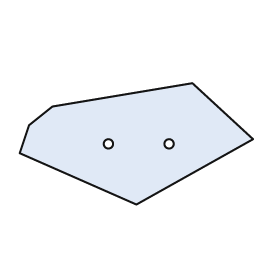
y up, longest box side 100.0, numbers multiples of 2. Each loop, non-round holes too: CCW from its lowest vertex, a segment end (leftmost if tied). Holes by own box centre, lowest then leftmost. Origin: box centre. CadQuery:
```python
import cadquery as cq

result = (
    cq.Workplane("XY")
    .moveTo(0.0, -26.0)
    .lineTo(50.0, 2.0)
    .lineTo(24.0, 26.0)
    .lineTo(-36.0, 16.0)
    .lineTo(-46.0, 8.0)
    .lineTo(-50.0, -4.0)
    .close()
    .moveTo(-12.0, 0.0)
    .circle(2.0)
    .moveTo(14.0, 0.0)
    .circle(2.0)
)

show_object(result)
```